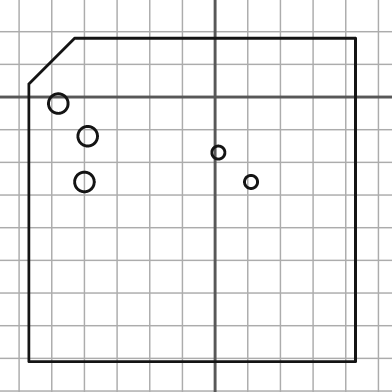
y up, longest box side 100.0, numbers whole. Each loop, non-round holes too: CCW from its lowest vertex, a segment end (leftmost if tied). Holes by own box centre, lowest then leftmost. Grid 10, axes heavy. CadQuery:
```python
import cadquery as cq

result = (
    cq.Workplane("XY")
    .moveTo(-57.0, -81.0)
    .lineTo(43.0, -81.0)
    .lineTo(43.0, 18.0)
    .lineTo(-43.0, 18.0)
    .lineTo(-57.0, 4.0)
    .close()
    .moveTo(-40.0, -26.0)
    .circle(3.0)
    .moveTo(11.0, -26.0)
    .circle(2.0)
    .moveTo(1.0, -17.0)
    .circle(2.0)
    .moveTo(-39.0, -12.0)
    .circle(3.0)
    .moveTo(-48.0, -2.0)
    .circle(3.0)
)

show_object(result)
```